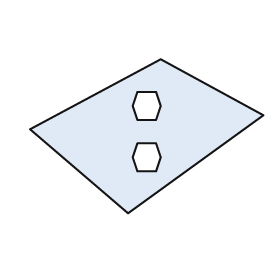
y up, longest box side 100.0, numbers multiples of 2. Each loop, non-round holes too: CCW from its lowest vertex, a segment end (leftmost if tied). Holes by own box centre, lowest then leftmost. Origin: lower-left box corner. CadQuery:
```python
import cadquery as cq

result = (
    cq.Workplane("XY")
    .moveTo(42.0, 0.0)
    .lineTo(100.0, 42.0)
    .lineTo(56.0, 66.0)
    .lineTo(0.0, 36.0)
    .close()
    .moveTo(46.0, 18.0)
    .lineTo(54.0, 18.0)
    .lineTo(56.0, 24.0)
    .lineTo(54.0, 30.0)
    .lineTo(46.0, 30.0)
    .lineTo(44.0, 24.0)
    .close()
    .moveTo(46.0, 40.0)
    .lineTo(54.0, 40.0)
    .lineTo(56.0, 46.0)
    .lineTo(54.0, 52.0)
    .lineTo(46.0, 52.0)
    .lineTo(44.0, 46.0)
    .close()
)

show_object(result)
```